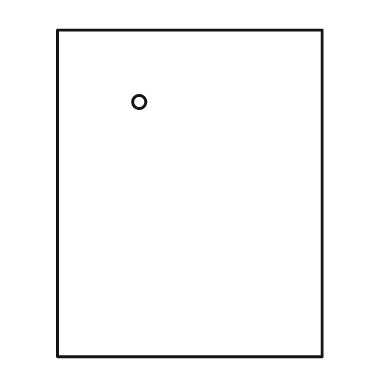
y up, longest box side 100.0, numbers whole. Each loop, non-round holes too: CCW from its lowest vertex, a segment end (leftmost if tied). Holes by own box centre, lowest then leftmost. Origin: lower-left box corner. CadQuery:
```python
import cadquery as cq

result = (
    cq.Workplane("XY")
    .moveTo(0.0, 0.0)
    .lineTo(81.0, 0.0)
    .lineTo(81.0, 100.0)
    .lineTo(0.0, 100.0)
    .close()
    .moveTo(25.0, 78.0)
    .circle(2.0)
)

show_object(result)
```